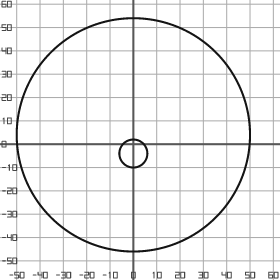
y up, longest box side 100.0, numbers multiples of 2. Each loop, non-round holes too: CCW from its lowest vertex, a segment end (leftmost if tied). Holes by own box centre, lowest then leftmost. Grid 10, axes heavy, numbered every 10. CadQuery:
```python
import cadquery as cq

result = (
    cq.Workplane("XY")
    .moveTo(0.0, 4.0)
    .circle(50.0)
    .moveTo(0.0, -4.0)
    .circle(6.0)
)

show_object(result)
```